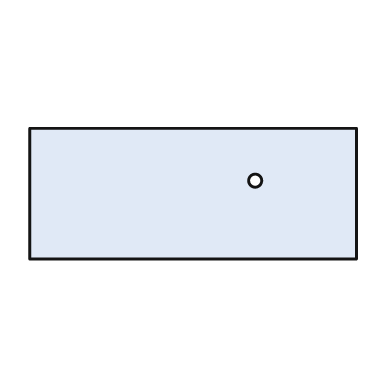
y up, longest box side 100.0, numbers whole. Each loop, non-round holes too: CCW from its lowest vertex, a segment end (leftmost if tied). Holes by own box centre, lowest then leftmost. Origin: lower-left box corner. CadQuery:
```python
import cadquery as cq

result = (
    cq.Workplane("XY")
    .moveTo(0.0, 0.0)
    .lineTo(100.0, 0.0)
    .lineTo(100.0, 40.0)
    .lineTo(0.0, 40.0)
    .close()
    .moveTo(69.0, 24.0)
    .circle(2.0)
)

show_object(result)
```